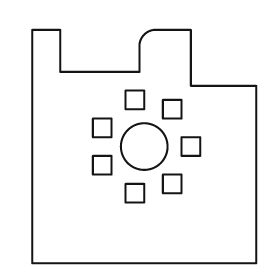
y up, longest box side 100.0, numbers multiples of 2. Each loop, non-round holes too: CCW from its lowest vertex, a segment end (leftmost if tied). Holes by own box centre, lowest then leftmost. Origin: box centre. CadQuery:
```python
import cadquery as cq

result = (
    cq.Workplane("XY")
    .moveTo(-48.0, -50.0)
    .lineTo(48.0, -50.0)
    .lineTo(48.0, 26.0)
    .lineTo(20.0, 26.0)
    .lineTo(20.0, 50.0)
    .lineTo(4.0, 50.0)
    .threePointArc((0.0, 48.0), (-2.0, 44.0))
    .lineTo(-2.0, 32.0)
    .lineTo(-36.0, 32.0)
    .lineTo(-36.0, 50.0)
    .lineTo(-48.0, 50.0)
    .close()
    .moveTo(-8.0, -24.0)
    .lineTo(0.0, -24.0)
    .lineTo(0.0, -16.0)
    .lineTo(-8.0, -16.0)
    .close()
    .moveTo(8.0, -20.0)
    .lineTo(16.0, -20.0)
    .lineTo(16.0, -12.0)
    .lineTo(8.0, -12.0)
    .close()
    .moveTo(-22.0, -12.0)
    .lineTo(-14.0, -12.0)
    .lineTo(-14.0, -4.0)
    .lineTo(-22.0, -4.0)
    .close()
    .moveTo(0.0, 0.0)
    .circle(10.0)
    .moveTo(16.0, -4.0)
    .lineTo(24.0, -4.0)
    .lineTo(24.0, 4.0)
    .lineTo(16.0, 4.0)
    .close()
    .moveTo(-22.0, 4.0)
    .lineTo(-14.0, 4.0)
    .lineTo(-14.0, 12.0)
    .lineTo(-22.0, 12.0)
    .close()
    .moveTo(8.0, 12.0)
    .lineTo(16.0, 12.0)
    .lineTo(16.0, 20.0)
    .lineTo(8.0, 20.0)
    .close()
    .moveTo(-8.0, 16.0)
    .lineTo(0.0, 16.0)
    .lineTo(0.0, 24.0)
    .lineTo(-8.0, 24.0)
    .close()
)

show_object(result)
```